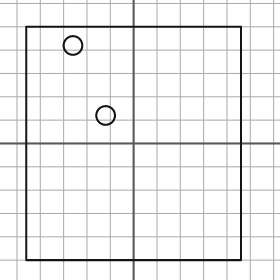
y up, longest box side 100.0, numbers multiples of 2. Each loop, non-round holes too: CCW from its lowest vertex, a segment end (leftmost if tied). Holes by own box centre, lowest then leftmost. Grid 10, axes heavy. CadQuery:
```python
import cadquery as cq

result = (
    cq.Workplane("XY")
    .moveTo(-46.0, -50.0)
    .lineTo(46.0, -50.0)
    .lineTo(46.0, 50.0)
    .lineTo(-46.0, 50.0)
    .close()
    .moveTo(-12.0, 12.0)
    .circle(4.0)
    .moveTo(-26.0, 42.0)
    .circle(4.0)
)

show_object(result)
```